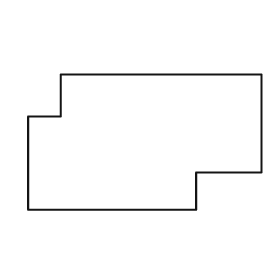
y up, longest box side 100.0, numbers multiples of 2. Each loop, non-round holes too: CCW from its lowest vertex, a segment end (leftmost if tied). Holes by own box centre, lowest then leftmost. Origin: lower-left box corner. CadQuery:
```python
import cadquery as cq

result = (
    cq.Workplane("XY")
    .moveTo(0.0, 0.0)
    .lineTo(72.0, 0.0)
    .lineTo(72.0, 16.0)
    .lineTo(100.0, 16.0)
    .lineTo(100.0, 58.0)
    .lineTo(14.0, 58.0)
    .lineTo(14.0, 40.0)
    .lineTo(0.0, 40.0)
    .close()
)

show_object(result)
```